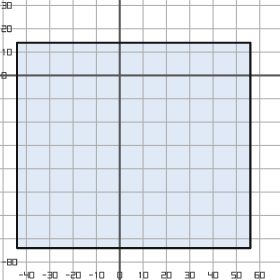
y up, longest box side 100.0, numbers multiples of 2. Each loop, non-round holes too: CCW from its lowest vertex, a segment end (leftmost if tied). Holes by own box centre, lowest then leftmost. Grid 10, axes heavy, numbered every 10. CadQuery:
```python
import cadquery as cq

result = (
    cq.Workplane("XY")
    .moveTo(-44.0, -74.0)
    .lineTo(56.0, -74.0)
    .lineTo(56.0, 14.0)
    .lineTo(-44.0, 14.0)
    .close()
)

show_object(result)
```